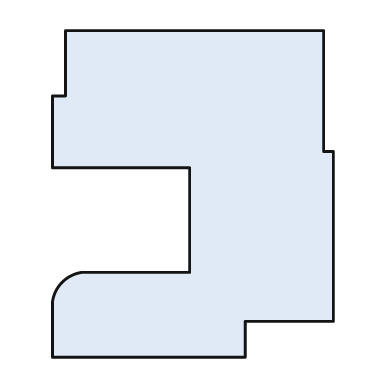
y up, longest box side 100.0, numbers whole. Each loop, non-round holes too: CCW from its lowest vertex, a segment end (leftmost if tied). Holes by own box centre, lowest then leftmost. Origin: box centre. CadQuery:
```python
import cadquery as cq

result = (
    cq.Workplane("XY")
    .moveTo(-43.0, -50.0)
    .lineTo(16.0, -50.0)
    .lineTo(16.0, -39.0)
    .lineTo(43.0, -39.0)
    .lineTo(43.0, 13.0)
    .lineTo(40.0, 13.0)
    .lineTo(40.0, 50.0)
    .lineTo(-39.0, 50.0)
    .lineTo(-39.0, 30.0)
    .lineTo(-43.0, 30.0)
    .lineTo(-43.0, 8.0)
    .lineTo(-1.0, 8.0)
    .lineTo(-1.0, -24.0)
    .lineTo(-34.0, -24.0)
    .threePointArc((-40.0, -27.0), (-43.0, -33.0))
    .close()
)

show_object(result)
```